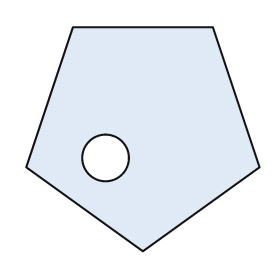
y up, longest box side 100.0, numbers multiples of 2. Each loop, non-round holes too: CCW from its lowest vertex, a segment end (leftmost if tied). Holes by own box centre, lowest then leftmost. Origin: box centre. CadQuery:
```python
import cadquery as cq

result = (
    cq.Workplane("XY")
    .moveTo(0.0, -48.0)
    .lineTo(50.0, -12.0)
    .lineTo(30.0, 48.0)
    .lineTo(-30.0, 48.0)
    .lineTo(-50.0, -12.0)
    .close()
    .moveTo(-16.0, -8.0)
    .circle(10.0)
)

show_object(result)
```